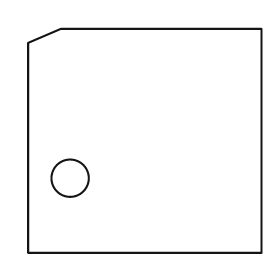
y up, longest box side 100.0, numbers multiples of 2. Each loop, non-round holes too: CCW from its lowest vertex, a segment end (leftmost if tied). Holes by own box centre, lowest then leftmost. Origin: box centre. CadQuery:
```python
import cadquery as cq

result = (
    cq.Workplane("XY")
    .moveTo(-50.0, -48.0)
    .lineTo(50.0, -48.0)
    .lineTo(50.0, 48.0)
    .lineTo(-36.0, 48.0)
    .lineTo(-50.0, 42.0)
    .close()
    .moveTo(-32.0, -16.0)
    .circle(8.0)
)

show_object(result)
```